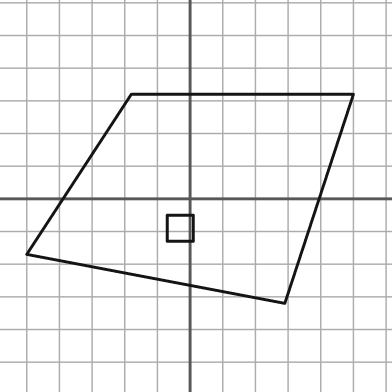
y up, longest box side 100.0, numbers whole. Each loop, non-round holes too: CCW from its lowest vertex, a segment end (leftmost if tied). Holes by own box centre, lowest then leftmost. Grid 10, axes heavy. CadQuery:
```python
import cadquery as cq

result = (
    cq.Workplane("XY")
    .moveTo(29.0, -32.0)
    .lineTo(50.0, 32.0)
    .lineTo(-18.0, 32.0)
    .lineTo(-50.0, -17.0)
    .close()
    .moveTo(-7.0, -13.0)
    .lineTo(1.0, -13.0)
    .lineTo(1.0, -5.0)
    .lineTo(-7.0, -5.0)
    .close()
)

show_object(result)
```